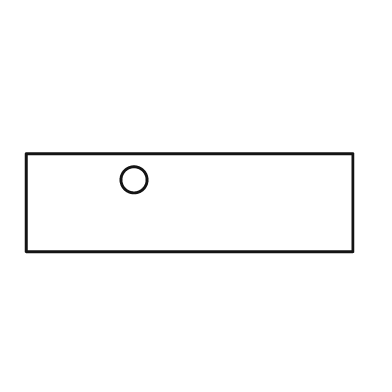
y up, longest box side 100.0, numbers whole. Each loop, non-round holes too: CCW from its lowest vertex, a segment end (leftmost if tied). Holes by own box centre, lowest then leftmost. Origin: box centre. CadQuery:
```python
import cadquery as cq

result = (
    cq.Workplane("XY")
    .moveTo(-50.0, -15.0)
    .lineTo(50.0, -15.0)
    .lineTo(50.0, 15.0)
    .lineTo(-50.0, 15.0)
    .close()
    .moveTo(-17.0, 7.0)
    .circle(4.0)
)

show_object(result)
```